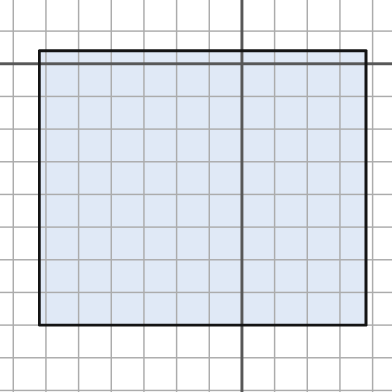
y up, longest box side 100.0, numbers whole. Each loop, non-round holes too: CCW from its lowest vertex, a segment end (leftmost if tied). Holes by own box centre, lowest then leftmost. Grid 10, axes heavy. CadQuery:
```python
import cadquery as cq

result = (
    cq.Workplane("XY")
    .moveTo(-62.0, -80.0)
    .lineTo(38.0, -80.0)
    .lineTo(38.0, 4.0)
    .lineTo(-62.0, 4.0)
    .close()
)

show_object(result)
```